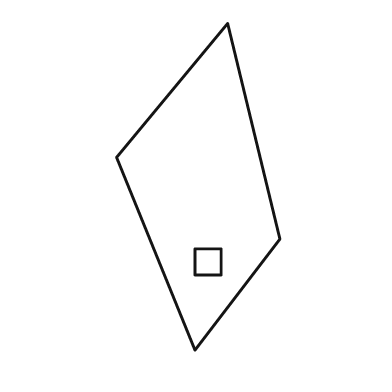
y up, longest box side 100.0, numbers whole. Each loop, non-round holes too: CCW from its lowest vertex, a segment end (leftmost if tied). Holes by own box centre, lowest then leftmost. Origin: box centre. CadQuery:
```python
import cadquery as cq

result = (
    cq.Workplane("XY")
    .moveTo(-1.0, -50.0)
    .lineTo(25.0, -16.0)
    .lineTo(9.0, 50.0)
    .lineTo(-25.0, 9.0)
    .close()
    .moveTo(-1.0, -27.0)
    .lineTo(7.0, -27.0)
    .lineTo(7.0, -19.0)
    .lineTo(-1.0, -19.0)
    .close()
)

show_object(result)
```